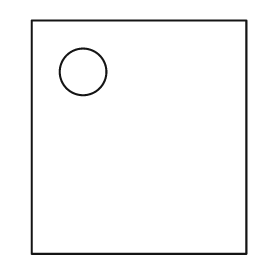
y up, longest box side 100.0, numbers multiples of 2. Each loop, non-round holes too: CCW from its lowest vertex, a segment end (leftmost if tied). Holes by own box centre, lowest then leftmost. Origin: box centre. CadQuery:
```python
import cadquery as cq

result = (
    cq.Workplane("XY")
    .moveTo(-46.0, -50.0)
    .lineTo(46.0, -50.0)
    .lineTo(46.0, 50.0)
    .lineTo(-46.0, 50.0)
    .close()
    .moveTo(-24.0, 28.0)
    .circle(10.0)
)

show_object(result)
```